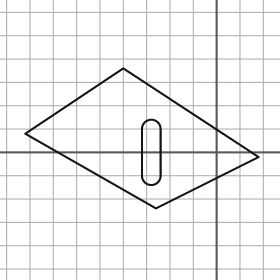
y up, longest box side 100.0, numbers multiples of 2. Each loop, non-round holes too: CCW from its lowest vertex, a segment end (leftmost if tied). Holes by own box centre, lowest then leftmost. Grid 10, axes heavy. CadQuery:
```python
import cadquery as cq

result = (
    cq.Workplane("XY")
    .moveTo(-26.0, -24.0)
    .lineTo(18.0, -2.0)
    .lineTo(-40.0, 36.0)
    .lineTo(-82.0, 8.0)
    .close()
    .moveTo(-32.0, -10.0)
    .threePointArc((-28.0, -14.0), (-24.0, -10.0))
    .lineTo(-24.0, 10.0)
    .threePointArc((-28.0, 14.0), (-32.0, 10.0))
    .close()
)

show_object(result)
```